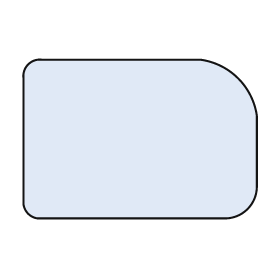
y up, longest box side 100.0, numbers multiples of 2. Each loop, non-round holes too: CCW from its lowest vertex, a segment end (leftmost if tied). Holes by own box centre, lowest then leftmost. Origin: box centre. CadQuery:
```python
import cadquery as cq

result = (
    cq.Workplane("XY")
    .moveTo(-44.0, -34.0)
    .lineTo(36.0, -34.0)
    .threePointArc((46.0, -30.0), (50.0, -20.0))
    .lineTo(50.0, 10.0)
    .threePointArc((42.0, 26.0), (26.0, 34.0))
    .lineTo(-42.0, 34.0)
    .threePointArc((-48.0, 32.0), (-50.0, 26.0))
    .lineTo(-50.0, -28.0)
    .threePointArc((-48.0, -32.0), (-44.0, -34.0))
    .close()
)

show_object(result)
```